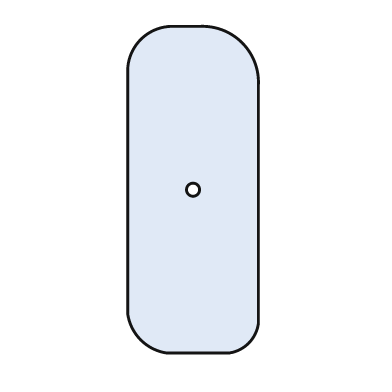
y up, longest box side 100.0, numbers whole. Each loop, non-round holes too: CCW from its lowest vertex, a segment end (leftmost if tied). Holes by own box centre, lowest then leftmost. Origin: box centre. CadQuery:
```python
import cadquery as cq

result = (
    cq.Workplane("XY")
    .moveTo(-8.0, -50.0)
    .lineTo(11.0, -50.0)
    .threePointArc((17.0, -47.0), (20.0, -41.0))
    .lineTo(20.0, 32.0)
    .threePointArc((15.0, 45.0), (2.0, 50.0))
    .lineTo(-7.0, 50.0)
    .threePointArc((-16.0, 46.0), (-20.0, 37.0))
    .lineTo(-20.0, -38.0)
    .threePointArc((-16.0, -46.0), (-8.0, -50.0))
    .close()
    .moveTo(0.0, 0.0)
    .circle(2.0)
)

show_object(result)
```